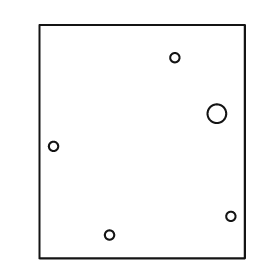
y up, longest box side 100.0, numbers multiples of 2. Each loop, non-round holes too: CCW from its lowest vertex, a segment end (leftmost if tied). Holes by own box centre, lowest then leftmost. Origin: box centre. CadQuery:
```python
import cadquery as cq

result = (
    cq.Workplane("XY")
    .moveTo(-44.0, -50.0)
    .lineTo(44.0, -50.0)
    .lineTo(44.0, 50.0)
    .lineTo(-44.0, 50.0)
    .close()
    .moveTo(-14.0, -40.0)
    .circle(2.0)
    .moveTo(38.0, -32.0)
    .circle(2.0)
    .moveTo(-38.0, -2.0)
    .circle(2.0)
    .moveTo(32.0, 12.0)
    .circle(4.0)
    .moveTo(14.0, 36.0)
    .circle(2.0)
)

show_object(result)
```